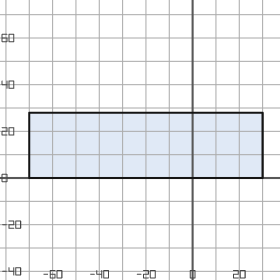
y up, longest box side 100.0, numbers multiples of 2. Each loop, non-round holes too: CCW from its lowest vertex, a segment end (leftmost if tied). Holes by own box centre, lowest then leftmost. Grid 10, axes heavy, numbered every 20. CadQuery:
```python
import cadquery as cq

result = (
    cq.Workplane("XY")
    .moveTo(-70.0, 0.0)
    .lineTo(30.0, 0.0)
    .lineTo(30.0, 28.0)
    .lineTo(-70.0, 28.0)
    .close()
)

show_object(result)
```